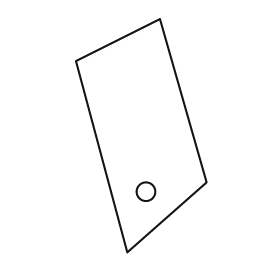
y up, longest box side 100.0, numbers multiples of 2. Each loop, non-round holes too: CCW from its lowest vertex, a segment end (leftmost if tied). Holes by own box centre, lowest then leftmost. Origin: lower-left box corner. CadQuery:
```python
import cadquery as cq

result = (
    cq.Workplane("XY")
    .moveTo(22.0, 0.0)
    .lineTo(56.0, 30.0)
    .lineTo(36.0, 100.0)
    .lineTo(0.0, 82.0)
    .close()
    .moveTo(30.0, 26.0)
    .circle(4.0)
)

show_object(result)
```